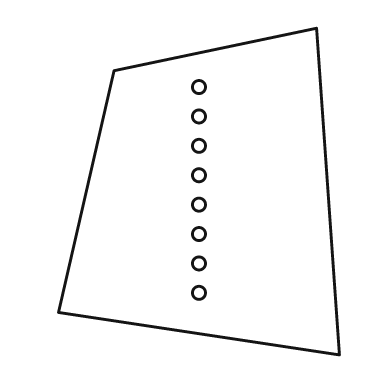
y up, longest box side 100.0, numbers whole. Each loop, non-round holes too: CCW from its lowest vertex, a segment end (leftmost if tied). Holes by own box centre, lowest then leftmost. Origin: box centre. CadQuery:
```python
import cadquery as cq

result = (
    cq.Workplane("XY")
    .moveTo(43.0, -50.0)
    .lineTo(36.0, 50.0)
    .lineTo(-26.0, 37.0)
    .lineTo(-43.0, -37.0)
    .close()
    .moveTo(0.0, -31.0)
    .circle(2.0)
    .moveTo(0.0, -22.0)
    .circle(2.0)
    .moveTo(0.0, -13.0)
    .circle(2.0)
    .moveTo(0.0, -4.0)
    .circle(2.0)
    .moveTo(0.0, 5.0)
    .circle(2.0)
    .moveTo(0.0, 14.0)
    .circle(2.0)
    .moveTo(0.0, 23.0)
    .circle(2.0)
    .moveTo(0.0, 32.0)
    .circle(2.0)
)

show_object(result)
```